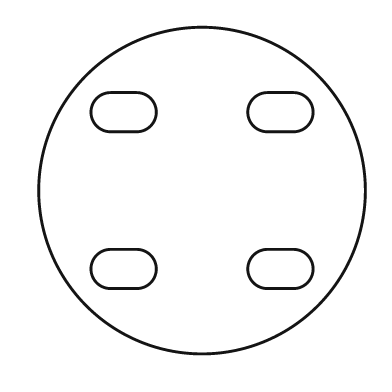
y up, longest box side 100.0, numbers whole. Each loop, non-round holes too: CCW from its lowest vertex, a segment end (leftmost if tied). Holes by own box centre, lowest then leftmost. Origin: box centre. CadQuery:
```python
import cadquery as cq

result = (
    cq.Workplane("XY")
    .moveTo(0.0, 0.0)
    .circle(50.0)
    .moveTo(-28.0, -30.0)
    .lineTo(-20.0, -30.0)
    .threePointArc((-14.0, -24.0), (-20.0, -18.0))
    .lineTo(-28.0, -18.0)
    .threePointArc((-34.0, -24.0), (-28.0, -30.0))
    .close()
    .moveTo(20.0, -30.0)
    .lineTo(28.0, -30.0)
    .threePointArc((34.0, -24.0), (28.0, -18.0))
    .lineTo(20.0, -18.0)
    .threePointArc((14.0, -24.0), (20.0, -30.0))
    .close()
    .moveTo(-28.0, 18.0)
    .lineTo(-20.0, 18.0)
    .threePointArc((-14.0, 24.0), (-20.0, 30.0))
    .lineTo(-28.0, 30.0)
    .threePointArc((-34.0, 24.0), (-28.0, 18.0))
    .close()
    .moveTo(20.0, 18.0)
    .lineTo(28.0, 18.0)
    .threePointArc((34.0, 24.0), (28.0, 30.0))
    .lineTo(20.0, 30.0)
    .threePointArc((14.0, 24.0), (20.0, 18.0))
    .close()
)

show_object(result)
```